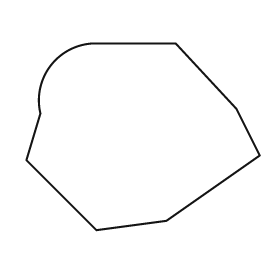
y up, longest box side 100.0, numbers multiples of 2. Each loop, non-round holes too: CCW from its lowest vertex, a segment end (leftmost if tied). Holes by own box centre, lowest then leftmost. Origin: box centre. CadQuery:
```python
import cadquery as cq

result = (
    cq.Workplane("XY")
    .moveTo(-20.0, -40.0)
    .lineTo(10.0, -36.0)
    .lineTo(50.0, -8.0)
    .lineTo(40.0, 12.0)
    .lineTo(14.0, 40.0)
    .lineTo(-22.0, 40.0)
    .threePointArc((-40.0, 30.0), (-44.0, 10.0))
    .lineTo(-50.0, -10.0)
    .close()
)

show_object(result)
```